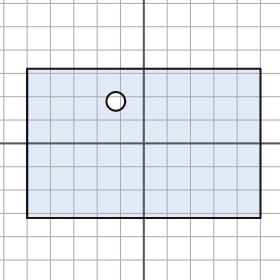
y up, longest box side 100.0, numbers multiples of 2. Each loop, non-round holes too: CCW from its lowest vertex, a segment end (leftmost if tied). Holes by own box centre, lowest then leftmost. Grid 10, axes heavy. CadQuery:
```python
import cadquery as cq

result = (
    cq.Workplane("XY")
    .moveTo(-50.0, -32.0)
    .lineTo(50.0, -32.0)
    .lineTo(50.0, 32.0)
    .lineTo(-50.0, 32.0)
    .close()
    .moveTo(-12.0, 18.0)
    .circle(4.0)
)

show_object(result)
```